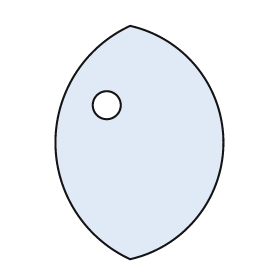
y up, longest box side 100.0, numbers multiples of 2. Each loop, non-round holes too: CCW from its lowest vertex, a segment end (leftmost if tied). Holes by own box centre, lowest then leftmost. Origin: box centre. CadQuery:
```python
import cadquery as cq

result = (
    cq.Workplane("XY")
    .moveTo(-4.0, -50.0)
    .threePointArc((36.0, 0.0), (-4.0, 50.0))
    .threePointArc((-36.0, 0.0), (-4.0, -50.0))
    .close()
    .moveTo(-14.0, 16.0)
    .circle(6.0)
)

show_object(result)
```